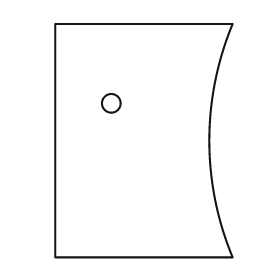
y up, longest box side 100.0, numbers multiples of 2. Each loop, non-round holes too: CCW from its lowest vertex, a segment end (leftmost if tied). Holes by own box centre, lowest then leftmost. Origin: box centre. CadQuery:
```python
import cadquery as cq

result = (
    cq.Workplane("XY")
    .moveTo(-38.0, -50.0)
    .lineTo(38.0, -50.0)
    .threePointArc((28.0, 0.0), (38.0, 50.0))
    .lineTo(-38.0, 50.0)
    .close()
    .moveTo(-14.0, 16.0)
    .circle(4.0)
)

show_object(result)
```